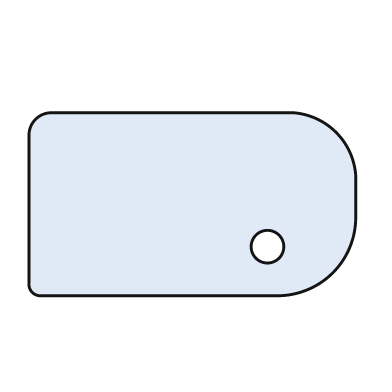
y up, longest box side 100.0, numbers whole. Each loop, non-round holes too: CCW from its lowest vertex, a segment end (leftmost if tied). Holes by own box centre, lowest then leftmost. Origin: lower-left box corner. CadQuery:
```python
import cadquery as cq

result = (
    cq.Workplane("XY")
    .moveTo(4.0, 0.0)
    .lineTo(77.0, 0.0)
    .threePointArc((93.0, 7.0), (100.0, 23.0))
    .lineTo(100.0, 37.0)
    .threePointArc((94.0, 50.0), (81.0, 56.0))
    .lineTo(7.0, 56.0)
    .threePointArc((2.0, 54.0), (0.0, 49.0))
    .lineTo(0.0, 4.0)
    .threePointArc((1.0, 1.0), (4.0, 0.0))
    .close()
    .moveTo(73.0, 15.0)
    .circle(5.0)
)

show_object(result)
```